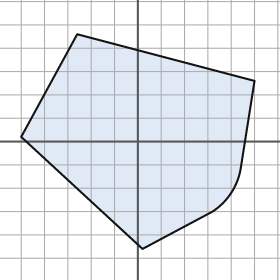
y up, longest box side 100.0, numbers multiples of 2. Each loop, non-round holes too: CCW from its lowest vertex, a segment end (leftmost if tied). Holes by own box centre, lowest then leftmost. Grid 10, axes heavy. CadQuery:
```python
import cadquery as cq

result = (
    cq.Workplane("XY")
    .moveTo(2.0, -46.0)
    .lineTo(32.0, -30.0)
    .threePointArc((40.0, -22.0), (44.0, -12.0))
    .lineTo(50.0, 26.0)
    .lineTo(-26.0, 46.0)
    .lineTo(-50.0, 2.0)
    .close()
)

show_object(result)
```